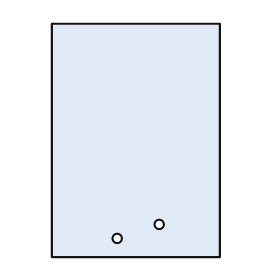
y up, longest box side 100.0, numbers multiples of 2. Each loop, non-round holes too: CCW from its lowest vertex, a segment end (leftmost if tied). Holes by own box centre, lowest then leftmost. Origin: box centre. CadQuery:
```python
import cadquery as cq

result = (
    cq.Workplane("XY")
    .moveTo(-36.0, -50.0)
    .lineTo(36.0, -50.0)
    .lineTo(36.0, 50.0)
    .lineTo(-36.0, 50.0)
    .close()
    .moveTo(-8.0, -42.0)
    .circle(2.0)
    .moveTo(10.0, -36.0)
    .circle(2.0)
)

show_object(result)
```